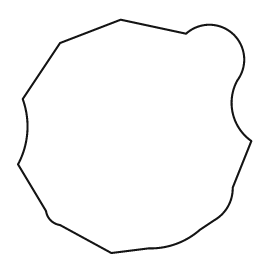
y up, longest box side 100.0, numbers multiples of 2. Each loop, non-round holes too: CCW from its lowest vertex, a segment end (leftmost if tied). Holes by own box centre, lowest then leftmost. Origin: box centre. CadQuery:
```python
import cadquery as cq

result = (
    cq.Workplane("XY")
    .moveTo(-10.0, -50.0)
    .lineTo(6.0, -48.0)
    .threePointArc((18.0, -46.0), (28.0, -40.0))
    .lineTo(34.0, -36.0)
    .threePointArc((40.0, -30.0), (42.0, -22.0))
    .lineTo(50.0, -2.0)
    .threePointArc((42.0, 10.0), (44.0, 24.0))
    .threePointArc((42.0, 44.0), (22.0, 44.0))
    .lineTo(-6.0, 50.0)
    .lineTo(-32.0, 40.0)
    .lineTo(-48.0, 16.0)
    .threePointArc((-46.0, 2.0), (-50.0, -12.0))
    .lineTo(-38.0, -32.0)
    .threePointArc((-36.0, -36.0), (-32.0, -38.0))
    .close()
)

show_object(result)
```